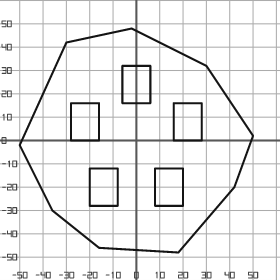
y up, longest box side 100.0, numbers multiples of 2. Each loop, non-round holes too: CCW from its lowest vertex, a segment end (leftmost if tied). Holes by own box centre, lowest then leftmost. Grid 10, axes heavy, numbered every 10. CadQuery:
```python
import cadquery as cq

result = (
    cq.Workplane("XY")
    .moveTo(18.0, -48.0)
    .lineTo(42.0, -20.0)
    .lineTo(50.0, 2.0)
    .lineTo(30.0, 32.0)
    .lineTo(-2.0, 48.0)
    .lineTo(-30.0, 42.0)
    .lineTo(-50.0, -2.0)
    .lineTo(-36.0, -30.0)
    .lineTo(-16.0, -46.0)
    .close()
    .moveTo(-20.0, -28.0)
    .lineTo(-8.0, -28.0)
    .lineTo(-8.0, -12.0)
    .lineTo(-20.0, -12.0)
    .close()
    .moveTo(8.0, -28.0)
    .lineTo(20.0, -28.0)
    .lineTo(20.0, -12.0)
    .lineTo(8.0, -12.0)
    .close()
    .moveTo(-28.0, 0.0)
    .lineTo(-16.0, 0.0)
    .lineTo(-16.0, 16.0)
    .lineTo(-28.0, 16.0)
    .close()
    .moveTo(16.0, 0.0)
    .lineTo(28.0, 0.0)
    .lineTo(28.0, 16.0)
    .lineTo(16.0, 16.0)
    .close()
    .moveTo(-6.0, 16.0)
    .lineTo(6.0, 16.0)
    .lineTo(6.0, 32.0)
    .lineTo(-6.0, 32.0)
    .close()
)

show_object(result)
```